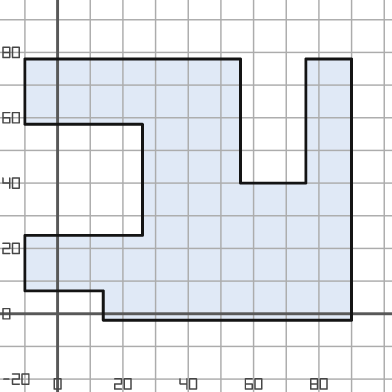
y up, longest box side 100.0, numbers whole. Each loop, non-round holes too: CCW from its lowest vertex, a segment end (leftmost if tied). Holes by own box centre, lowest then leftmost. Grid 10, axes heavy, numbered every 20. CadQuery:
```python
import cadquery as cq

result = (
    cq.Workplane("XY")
    .moveTo(14.0, -2.0)
    .lineTo(90.0, -2.0)
    .lineTo(90.0, 78.0)
    .lineTo(76.0, 78.0)
    .lineTo(76.0, 40.0)
    .lineTo(56.0, 40.0)
    .lineTo(56.0, 78.0)
    .lineTo(-10.0, 78.0)
    .lineTo(-10.0, 58.0)
    .lineTo(26.0, 58.0)
    .lineTo(26.0, 24.0)
    .lineTo(-10.0, 24.0)
    .lineTo(-10.0, 7.0)
    .lineTo(14.0, 7.0)
    .close()
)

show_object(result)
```